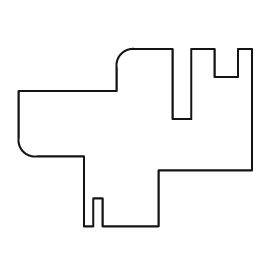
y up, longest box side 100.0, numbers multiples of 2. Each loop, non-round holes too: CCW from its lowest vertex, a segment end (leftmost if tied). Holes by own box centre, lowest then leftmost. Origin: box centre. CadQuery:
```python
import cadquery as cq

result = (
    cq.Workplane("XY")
    .moveTo(-22.0, -38.0)
    .lineTo(-18.0, -38.0)
    .lineTo(-18.0, -26.0)
    .lineTo(-14.0, -26.0)
    .lineTo(-14.0, -38.0)
    .lineTo(10.0, -38.0)
    .lineTo(10.0, -14.0)
    .lineTo(50.0, -14.0)
    .lineTo(50.0, 38.0)
    .lineTo(44.0, 38.0)
    .lineTo(44.0, 26.0)
    .lineTo(34.0, 26.0)
    .lineTo(34.0, 38.0)
    .lineTo(24.0, 38.0)
    .lineTo(24.0, 8.0)
    .lineTo(16.0, 8.0)
    .lineTo(16.0, 38.0)
    .lineTo(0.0, 38.0)
    .threePointArc((-6.0, 36.0), (-8.0, 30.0))
    .lineTo(-8.0, 20.0)
    .lineTo(-50.0, 20.0)
    .lineTo(-50.0, 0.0)
    .threePointArc((-48.0, -6.0), (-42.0, -8.0))
    .lineTo(-22.0, -8.0)
    .close()
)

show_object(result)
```